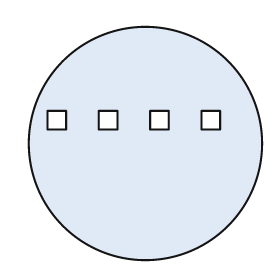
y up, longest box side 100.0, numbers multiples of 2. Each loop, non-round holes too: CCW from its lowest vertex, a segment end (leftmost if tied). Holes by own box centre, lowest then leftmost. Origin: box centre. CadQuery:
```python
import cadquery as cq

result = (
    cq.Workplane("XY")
    .moveTo(0.0, 0.0)
    .circle(50.0)
    .moveTo(-42.0, 6.0)
    .lineTo(-34.0, 6.0)
    .lineTo(-34.0, 14.0)
    .lineTo(-42.0, 14.0)
    .close()
    .moveTo(-20.0, 6.0)
    .lineTo(-12.0, 6.0)
    .lineTo(-12.0, 14.0)
    .lineTo(-20.0, 14.0)
    .close()
    .moveTo(2.0, 6.0)
    .lineTo(10.0, 6.0)
    .lineTo(10.0, 14.0)
    .lineTo(2.0, 14.0)
    .close()
    .moveTo(24.0, 6.0)
    .lineTo(32.0, 6.0)
    .lineTo(32.0, 14.0)
    .lineTo(24.0, 14.0)
    .close()
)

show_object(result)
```